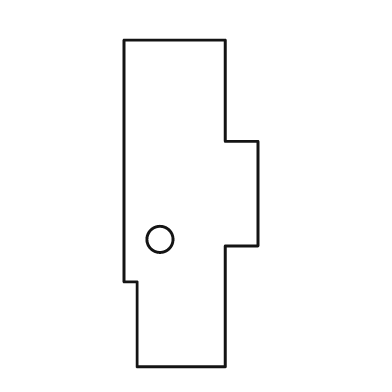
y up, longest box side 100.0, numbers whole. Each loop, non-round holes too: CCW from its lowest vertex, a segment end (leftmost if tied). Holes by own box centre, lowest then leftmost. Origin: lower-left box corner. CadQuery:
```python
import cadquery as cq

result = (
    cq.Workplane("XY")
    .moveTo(4.0, 0.0)
    .lineTo(31.0, 0.0)
    .lineTo(31.0, 37.0)
    .lineTo(41.0, 37.0)
    .lineTo(41.0, 69.0)
    .lineTo(31.0, 69.0)
    .lineTo(31.0, 100.0)
    .lineTo(0.0, 100.0)
    .lineTo(0.0, 26.0)
    .lineTo(4.0, 26.0)
    .close()
    .moveTo(11.0, 39.0)
    .circle(4.0)
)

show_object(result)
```